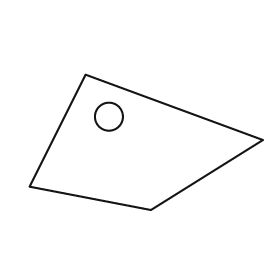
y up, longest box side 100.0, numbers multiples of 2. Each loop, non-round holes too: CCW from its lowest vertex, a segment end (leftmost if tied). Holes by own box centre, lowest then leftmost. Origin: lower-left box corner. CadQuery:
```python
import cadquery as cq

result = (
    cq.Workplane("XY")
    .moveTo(52.0, 0.0)
    .lineTo(100.0, 30.0)
    .lineTo(24.0, 58.0)
    .lineTo(0.0, 10.0)
    .close()
    .moveTo(34.0, 40.0)
    .circle(6.0)
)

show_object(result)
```